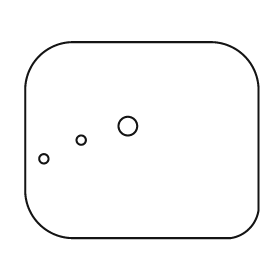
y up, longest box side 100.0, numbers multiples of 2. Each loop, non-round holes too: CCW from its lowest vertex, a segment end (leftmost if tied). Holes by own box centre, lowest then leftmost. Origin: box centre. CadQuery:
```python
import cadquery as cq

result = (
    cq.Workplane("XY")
    .moveTo(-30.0, -42.0)
    .lineTo(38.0, -42.0)
    .threePointArc((46.0, -38.0), (50.0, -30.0))
    .lineTo(50.0, 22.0)
    .threePointArc((44.0, 36.0), (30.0, 42.0))
    .lineTo(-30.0, 42.0)
    .threePointArc((-44.0, 36.0), (-50.0, 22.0))
    .lineTo(-50.0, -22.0)
    .threePointArc((-44.0, -36.0), (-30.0, -42.0))
    .close()
    .moveTo(-42.0, -8.0)
    .circle(2.0)
    .moveTo(-26.0, 0.0)
    .circle(2.0)
    .moveTo(-6.0, 6.0)
    .circle(4.0)
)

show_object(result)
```